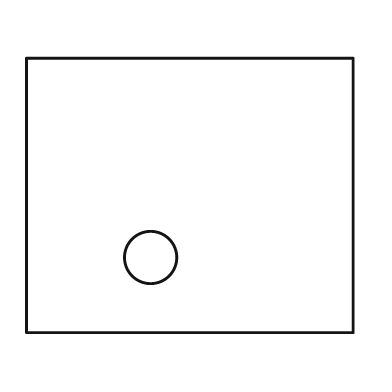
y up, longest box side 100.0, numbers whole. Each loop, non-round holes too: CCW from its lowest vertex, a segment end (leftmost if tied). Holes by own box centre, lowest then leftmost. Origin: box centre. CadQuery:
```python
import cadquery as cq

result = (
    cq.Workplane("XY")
    .moveTo(-50.0, -42.0)
    .lineTo(50.0, -42.0)
    .lineTo(50.0, 42.0)
    .lineTo(-50.0, 42.0)
    .close()
    .moveTo(-12.0, -19.0)
    .circle(8.0)
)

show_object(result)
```